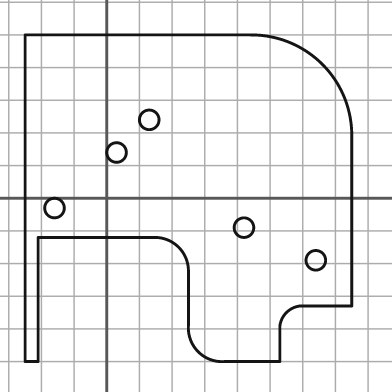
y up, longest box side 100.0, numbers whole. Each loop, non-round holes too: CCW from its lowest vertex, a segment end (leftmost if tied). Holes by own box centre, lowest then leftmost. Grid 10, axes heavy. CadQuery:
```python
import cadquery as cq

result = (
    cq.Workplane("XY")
    .moveTo(-25.0, -50.0)
    .lineTo(-21.0, -50.0)
    .lineTo(-21.0, -12.0)
    .lineTo(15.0, -12.0)
    .threePointArc((22.0, -15.0), (25.0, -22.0))
    .lineTo(25.0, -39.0)
    .threePointArc((28.0, -47.0), (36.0, -50.0))
    .lineTo(53.0, -50.0)
    .lineTo(53.0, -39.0)
    .threePointArc((55.0, -35.0), (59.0, -33.0))
    .lineTo(75.0, -33.0)
    .lineTo(75.0, 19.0)
    .threePointArc((66.0, 41.0), (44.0, 50.0))
    .lineTo(-25.0, 50.0)
    .close()
    .moveTo(64.0, -19.0)
    .circle(3.0)
    .moveTo(42.0, -9.0)
    .circle(3.0)
    .moveTo(-16.0, -3.0)
    .circle(3.0)
    .moveTo(3.0, 14.0)
    .circle(3.0)
    .moveTo(13.0, 24.0)
    .circle(3.0)
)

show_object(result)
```